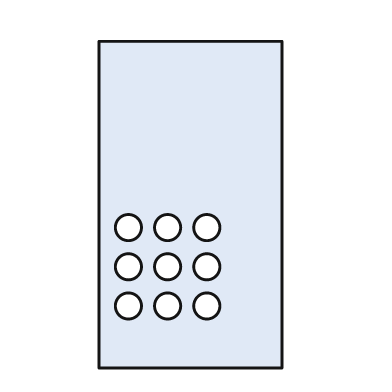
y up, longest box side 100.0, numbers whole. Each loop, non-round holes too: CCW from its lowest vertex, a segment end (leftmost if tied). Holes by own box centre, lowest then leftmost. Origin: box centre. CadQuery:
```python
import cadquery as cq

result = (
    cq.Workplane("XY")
    .moveTo(-28.0, -50.0)
    .lineTo(28.0, -50.0)
    .lineTo(28.0, 50.0)
    .lineTo(-28.0, 50.0)
    .close()
    .moveTo(-19.0, -31.0)
    .circle(4.0)
    .moveTo(-7.0, -31.0)
    .circle(4.0)
    .moveTo(5.0, -31.0)
    .circle(4.0)
    .moveTo(-19.0, -19.0)
    .circle(4.0)
    .moveTo(-7.0, -19.0)
    .circle(4.0)
    .moveTo(5.0, -19.0)
    .circle(4.0)
    .moveTo(-19.0, -7.0)
    .circle(4.0)
    .moveTo(-7.0, -7.0)
    .circle(4.0)
    .moveTo(5.0, -7.0)
    .circle(4.0)
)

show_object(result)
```